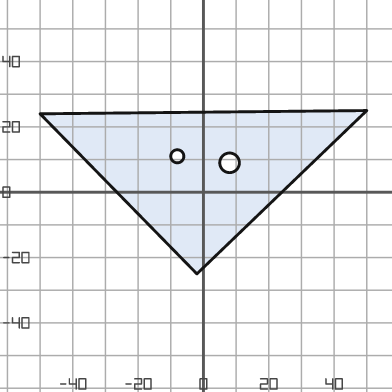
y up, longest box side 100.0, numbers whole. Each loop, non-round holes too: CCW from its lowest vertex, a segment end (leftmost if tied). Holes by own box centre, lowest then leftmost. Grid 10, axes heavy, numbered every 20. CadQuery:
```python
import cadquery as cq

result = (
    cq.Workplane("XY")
    .moveTo(-2.0, -25.0)
    .lineTo(50.0, 25.0)
    .lineTo(-50.0, 24.0)
    .close()
    .moveTo(8.0, 9.0)
    .circle(3.0)
    .moveTo(-8.0, 11.0)
    .circle(2.0)
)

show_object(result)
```